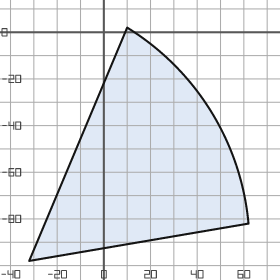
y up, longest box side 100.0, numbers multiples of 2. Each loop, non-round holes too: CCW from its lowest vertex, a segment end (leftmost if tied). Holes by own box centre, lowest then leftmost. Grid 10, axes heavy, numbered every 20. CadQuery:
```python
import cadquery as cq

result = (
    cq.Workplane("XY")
    .moveTo(-32.0, -98.0)
    .lineTo(62.0, -82.0)
    .threePointArc((46.0, -34.0), (10.0, 2.0))
    .close()
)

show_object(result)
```